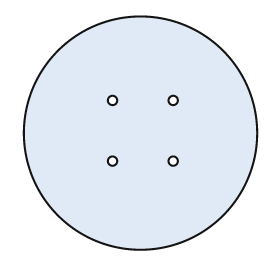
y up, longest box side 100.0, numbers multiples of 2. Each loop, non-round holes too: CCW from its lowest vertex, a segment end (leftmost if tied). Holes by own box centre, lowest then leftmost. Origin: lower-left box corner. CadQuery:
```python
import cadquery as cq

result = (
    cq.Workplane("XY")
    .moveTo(50.0, 50.0)
    .circle(50.0)
    .moveTo(38.0, 38.0)
    .circle(2.0)
    .moveTo(64.0, 38.0)
    .circle(2.0)
    .moveTo(38.0, 64.0)
    .circle(2.0)
    .moveTo(64.0, 64.0)
    .circle(2.0)
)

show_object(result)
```